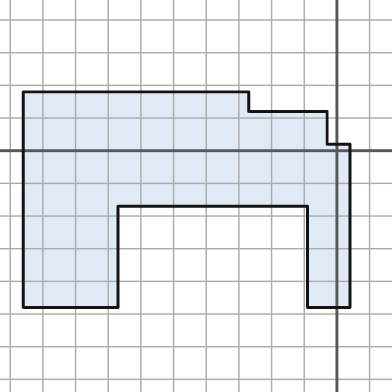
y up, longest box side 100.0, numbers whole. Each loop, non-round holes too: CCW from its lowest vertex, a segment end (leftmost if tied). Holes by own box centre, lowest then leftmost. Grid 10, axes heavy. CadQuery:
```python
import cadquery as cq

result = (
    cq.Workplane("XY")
    .moveTo(-96.0, -48.0)
    .lineTo(-67.0, -48.0)
    .lineTo(-67.0, -17.0)
    .lineTo(-9.0, -17.0)
    .lineTo(-9.0, -48.0)
    .lineTo(4.0, -48.0)
    .lineTo(4.0, 2.0)
    .lineTo(-3.0, 2.0)
    .lineTo(-3.0, 12.0)
    .lineTo(-27.0, 12.0)
    .lineTo(-27.0, 18.0)
    .lineTo(-96.0, 18.0)
    .close()
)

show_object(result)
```